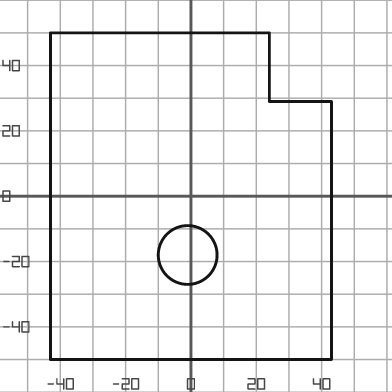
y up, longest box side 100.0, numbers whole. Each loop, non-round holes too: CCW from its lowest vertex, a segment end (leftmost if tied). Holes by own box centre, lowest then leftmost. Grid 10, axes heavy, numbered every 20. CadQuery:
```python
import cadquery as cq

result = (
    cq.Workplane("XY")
    .moveTo(-43.0, -50.0)
    .lineTo(43.0, -50.0)
    .lineTo(43.0, 29.0)
    .lineTo(24.0, 29.0)
    .lineTo(24.0, 50.0)
    .lineTo(-43.0, 50.0)
    .close()
    .moveTo(-1.0, -18.0)
    .circle(9.0)
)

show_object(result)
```